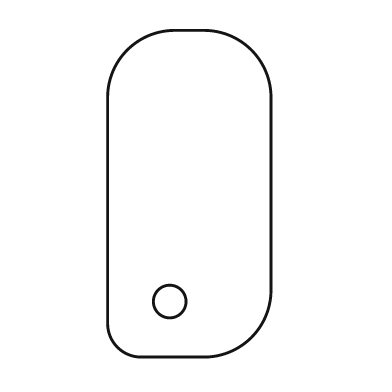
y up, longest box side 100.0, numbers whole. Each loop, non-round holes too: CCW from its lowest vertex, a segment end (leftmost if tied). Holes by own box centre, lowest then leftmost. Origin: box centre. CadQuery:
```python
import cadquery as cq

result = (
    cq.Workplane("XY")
    .moveTo(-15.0, -50.0)
    .lineTo(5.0, -50.0)
    .threePointArc((19.0, -44.0), (25.0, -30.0))
    .lineTo(25.0, 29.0)
    .threePointArc((19.0, 44.0), (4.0, 50.0))
    .lineTo(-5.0, 50.0)
    .threePointArc((-19.0, 44.0), (-25.0, 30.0))
    .lineTo(-25.0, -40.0)
    .threePointArc((-22.0, -47.0), (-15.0, -50.0))
    .close()
    .moveTo(-6.0, -33.0)
    .circle(5.0)
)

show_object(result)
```